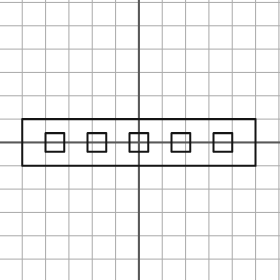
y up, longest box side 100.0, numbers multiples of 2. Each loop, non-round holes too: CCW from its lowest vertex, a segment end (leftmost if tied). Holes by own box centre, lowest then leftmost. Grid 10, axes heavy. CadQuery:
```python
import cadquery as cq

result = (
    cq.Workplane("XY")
    .moveTo(-50.0, -10.0)
    .lineTo(50.0, -10.0)
    .lineTo(50.0, 10.0)
    .lineTo(-50.0, 10.0)
    .close()
    .moveTo(-40.0, -4.0)
    .lineTo(-32.0, -4.0)
    .lineTo(-32.0, 4.0)
    .lineTo(-40.0, 4.0)
    .close()
    .moveTo(-22.0, -4.0)
    .lineTo(-14.0, -4.0)
    .lineTo(-14.0, 4.0)
    .lineTo(-22.0, 4.0)
    .close()
    .moveTo(-4.0, -4.0)
    .lineTo(4.0, -4.0)
    .lineTo(4.0, 4.0)
    .lineTo(-4.0, 4.0)
    .close()
    .moveTo(14.0, -4.0)
    .lineTo(22.0, -4.0)
    .lineTo(22.0, 4.0)
    .lineTo(14.0, 4.0)
    .close()
    .moveTo(32.0, -4.0)
    .lineTo(40.0, -4.0)
    .lineTo(40.0, 4.0)
    .lineTo(32.0, 4.0)
    .close()
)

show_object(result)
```